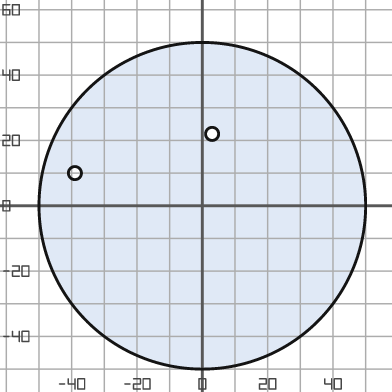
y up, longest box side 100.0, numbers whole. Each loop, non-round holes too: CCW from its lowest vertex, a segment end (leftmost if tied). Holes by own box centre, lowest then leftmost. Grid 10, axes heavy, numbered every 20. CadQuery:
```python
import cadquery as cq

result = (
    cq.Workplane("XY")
    .moveTo(0.0, 0.0)
    .circle(50.0)
    .moveTo(-39.0, 10.0)
    .circle(2.0)
    .moveTo(3.0, 22.0)
    .circle(2.0)
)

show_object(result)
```